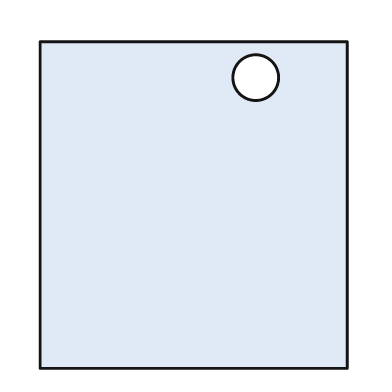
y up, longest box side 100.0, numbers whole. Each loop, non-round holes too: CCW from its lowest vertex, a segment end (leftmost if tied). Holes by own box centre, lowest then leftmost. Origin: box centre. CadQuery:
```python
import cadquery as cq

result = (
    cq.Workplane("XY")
    .moveTo(-47.0, -50.0)
    .lineTo(47.0, -50.0)
    .lineTo(47.0, 50.0)
    .lineTo(-47.0, 50.0)
    .close()
    .moveTo(19.0, 39.0)
    .circle(7.0)
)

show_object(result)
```